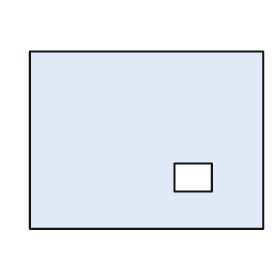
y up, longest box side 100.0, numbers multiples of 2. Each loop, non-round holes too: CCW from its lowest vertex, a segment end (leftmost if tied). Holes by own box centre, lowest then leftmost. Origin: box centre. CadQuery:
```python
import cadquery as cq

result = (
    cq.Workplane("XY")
    .moveTo(-50.0, -38.0)
    .lineTo(50.0, -38.0)
    .lineTo(50.0, 38.0)
    .lineTo(-50.0, 38.0)
    .close()
    .moveTo(12.0, -22.0)
    .lineTo(28.0, -22.0)
    .lineTo(28.0, -10.0)
    .lineTo(12.0, -10.0)
    .close()
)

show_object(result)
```